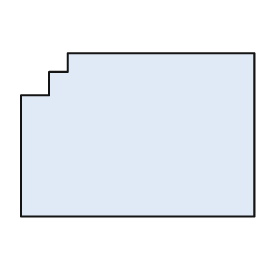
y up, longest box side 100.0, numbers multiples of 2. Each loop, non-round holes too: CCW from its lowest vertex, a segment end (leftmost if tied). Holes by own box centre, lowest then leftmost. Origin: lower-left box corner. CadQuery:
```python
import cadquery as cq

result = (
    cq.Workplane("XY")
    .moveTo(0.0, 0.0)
    .lineTo(100.0, 0.0)
    .lineTo(100.0, 70.0)
    .lineTo(20.0, 70.0)
    .lineTo(20.0, 62.0)
    .lineTo(12.0, 62.0)
    .lineTo(12.0, 52.0)
    .lineTo(0.0, 52.0)
    .close()
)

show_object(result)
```